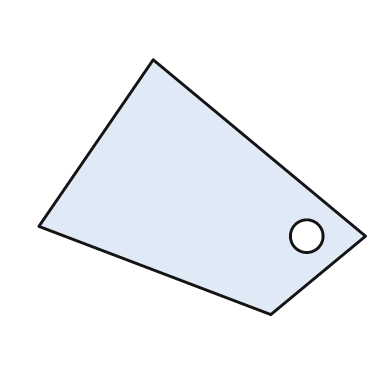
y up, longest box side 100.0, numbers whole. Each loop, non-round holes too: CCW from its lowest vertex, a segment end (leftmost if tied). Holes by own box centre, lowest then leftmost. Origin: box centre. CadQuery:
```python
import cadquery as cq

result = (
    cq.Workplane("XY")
    .moveTo(21.0, -39.0)
    .lineTo(50.0, -15.0)
    .lineTo(-15.0, 39.0)
    .lineTo(-50.0, -12.0)
    .close()
    .moveTo(32.0, -15.0)
    .circle(5.0)
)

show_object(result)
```